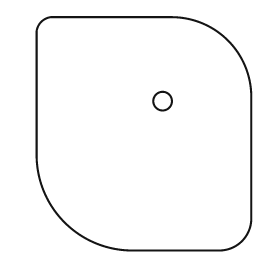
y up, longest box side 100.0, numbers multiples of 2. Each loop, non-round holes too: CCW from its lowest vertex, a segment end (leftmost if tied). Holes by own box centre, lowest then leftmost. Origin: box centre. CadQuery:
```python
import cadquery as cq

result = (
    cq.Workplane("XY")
    .moveTo(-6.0, -50.0)
    .lineTo(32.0, -50.0)
    .threePointArc((42.0, -46.0), (46.0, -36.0))
    .lineTo(46.0, 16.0)
    .threePointArc((36.0, 40.0), (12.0, 50.0))
    .lineTo(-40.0, 50.0)
    .threePointArc((-44.0, 48.0), (-46.0, 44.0))
    .lineTo(-46.0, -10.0)
    .threePointArc((-34.0, -38.0), (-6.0, -50.0))
    .close()
    .moveTo(8.0, 14.0)
    .circle(4.0)
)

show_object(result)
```